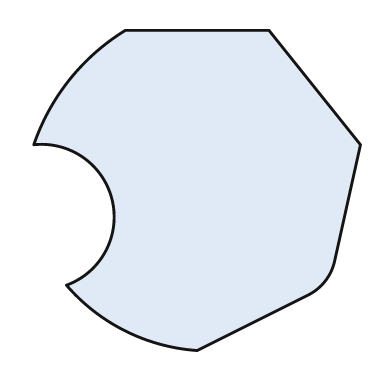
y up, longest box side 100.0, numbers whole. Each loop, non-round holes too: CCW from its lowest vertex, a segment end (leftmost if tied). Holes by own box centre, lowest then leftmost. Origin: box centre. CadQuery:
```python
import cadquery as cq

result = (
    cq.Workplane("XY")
    .moveTo(0.0, -49.0)
    .lineTo(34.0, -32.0)
    .threePointArc((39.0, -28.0), (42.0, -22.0))
    .lineTo(50.0, 14.0)
    .lineTo(22.0, 49.0)
    .lineTo(-22.0, 49.0)
    .threePointArc((-39.0, 34.0), (-50.0, 14.0))
    .threePointArc((-26.0, -3.0), (-40.0, -29.0))
    .threePointArc((-22.0, -43.0), (0.0, -49.0))
    .close()
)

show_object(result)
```